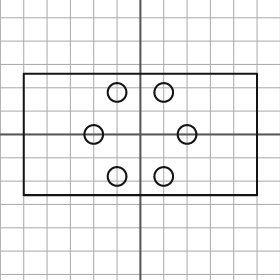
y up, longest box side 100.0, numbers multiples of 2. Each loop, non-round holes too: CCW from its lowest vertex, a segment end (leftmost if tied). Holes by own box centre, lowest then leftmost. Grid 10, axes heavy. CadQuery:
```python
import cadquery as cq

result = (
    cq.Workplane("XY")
    .moveTo(-50.0, -26.0)
    .lineTo(50.0, -26.0)
    .lineTo(50.0, 26.0)
    .lineTo(-50.0, 26.0)
    .close()
    .moveTo(-10.0, -18.0)
    .circle(4.0)
    .moveTo(10.0, -18.0)
    .circle(4.0)
    .moveTo(-20.0, 0.0)
    .circle(4.0)
    .moveTo(20.0, 0.0)
    .circle(4.0)
    .moveTo(-10.0, 18.0)
    .circle(4.0)
    .moveTo(10.0, 18.0)
    .circle(4.0)
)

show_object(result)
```